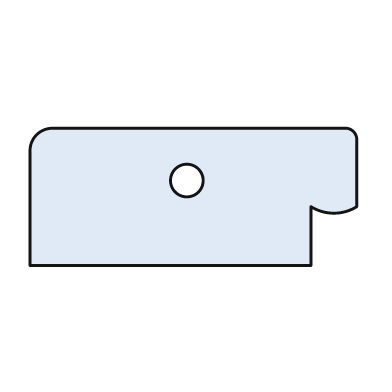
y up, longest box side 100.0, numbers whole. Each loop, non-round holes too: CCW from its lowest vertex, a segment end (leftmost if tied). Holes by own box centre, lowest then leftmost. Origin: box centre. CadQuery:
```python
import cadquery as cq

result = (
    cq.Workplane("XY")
    .moveTo(-50.0, -21.0)
    .lineTo(36.0, -21.0)
    .lineTo(36.0, -3.0)
    .threePointArc((43.0, -5.0), (50.0, -3.0))
    .lineTo(50.0, 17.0)
    .threePointArc((49.0, 20.0), (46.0, 21.0))
    .lineTo(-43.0, 21.0)
    .threePointArc((-48.0, 19.0), (-50.0, 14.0))
    .close()
    .moveTo(-2.0, 5.0)
    .circle(5.0)
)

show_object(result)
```